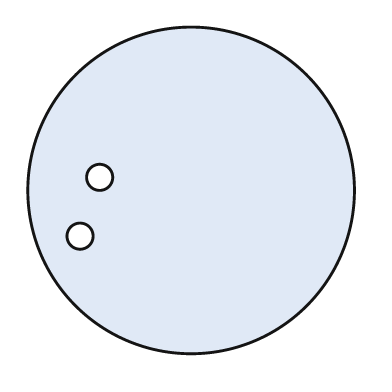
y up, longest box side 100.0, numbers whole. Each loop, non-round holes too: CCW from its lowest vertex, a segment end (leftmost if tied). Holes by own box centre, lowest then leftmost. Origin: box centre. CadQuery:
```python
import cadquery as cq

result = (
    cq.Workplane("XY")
    .moveTo(0.0, 0.0)
    .circle(50.0)
    .moveTo(-34.0, -14.0)
    .circle(4.0)
    .moveTo(-28.0, 4.0)
    .circle(4.0)
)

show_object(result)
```